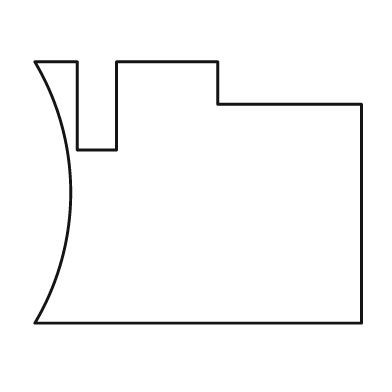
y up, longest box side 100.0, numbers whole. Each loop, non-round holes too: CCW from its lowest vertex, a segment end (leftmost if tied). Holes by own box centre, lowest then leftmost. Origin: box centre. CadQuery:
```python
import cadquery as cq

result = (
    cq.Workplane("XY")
    .moveTo(-50.0, -40.0)
    .lineTo(50.0, -40.0)
    .lineTo(50.0, 27.0)
    .lineTo(6.0, 27.0)
    .lineTo(6.0, 40.0)
    .lineTo(-25.0, 40.0)
    .lineTo(-25.0, 13.0)
    .lineTo(-37.0, 13.0)
    .lineTo(-37.0, 40.0)
    .lineTo(-50.0, 40.0)
    .threePointArc((-39.0, 0.0), (-50.0, -40.0))
    .close()
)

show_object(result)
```